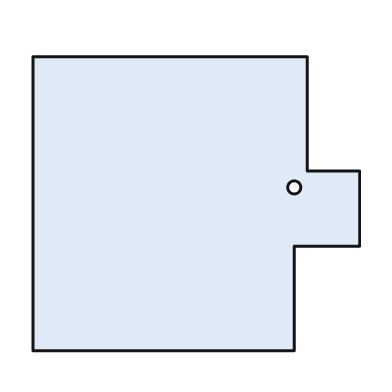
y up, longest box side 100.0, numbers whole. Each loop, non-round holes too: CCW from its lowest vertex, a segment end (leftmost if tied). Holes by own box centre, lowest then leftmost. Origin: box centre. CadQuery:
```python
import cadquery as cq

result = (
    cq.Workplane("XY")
    .moveTo(-50.0, -45.0)
    .lineTo(30.0, -45.0)
    .lineTo(30.0, -13.0)
    .lineTo(50.0, -13.0)
    .lineTo(50.0, 10.0)
    .lineTo(34.0, 10.0)
    .lineTo(34.0, 45.0)
    .lineTo(-50.0, 45.0)
    .close()
    .moveTo(30.0, 5.0)
    .circle(2.0)
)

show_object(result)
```